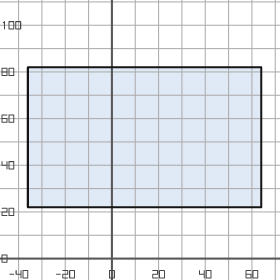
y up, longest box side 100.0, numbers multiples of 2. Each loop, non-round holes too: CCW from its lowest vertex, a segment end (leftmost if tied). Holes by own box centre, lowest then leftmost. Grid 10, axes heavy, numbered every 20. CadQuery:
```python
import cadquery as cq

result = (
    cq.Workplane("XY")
    .moveTo(-36.0, 22.0)
    .lineTo(64.0, 22.0)
    .lineTo(64.0, 82.0)
    .lineTo(-36.0, 82.0)
    .close()
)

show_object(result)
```